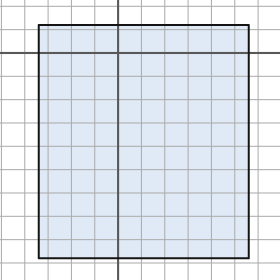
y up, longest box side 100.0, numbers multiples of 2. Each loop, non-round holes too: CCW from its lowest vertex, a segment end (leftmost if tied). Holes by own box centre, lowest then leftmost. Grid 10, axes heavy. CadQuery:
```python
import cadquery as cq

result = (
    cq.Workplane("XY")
    .moveTo(-34.0, -88.0)
    .lineTo(56.0, -88.0)
    .lineTo(56.0, 12.0)
    .lineTo(-34.0, 12.0)
    .close()
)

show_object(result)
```